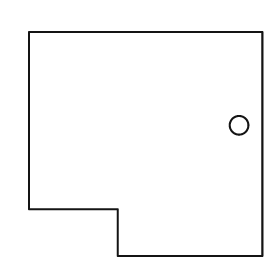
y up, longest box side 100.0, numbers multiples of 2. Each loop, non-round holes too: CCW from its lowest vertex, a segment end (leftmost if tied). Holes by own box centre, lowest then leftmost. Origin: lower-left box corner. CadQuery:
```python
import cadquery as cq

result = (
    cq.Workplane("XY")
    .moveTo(38.0, 0.0)
    .lineTo(100.0, 0.0)
    .lineTo(100.0, 96.0)
    .lineTo(0.0, 96.0)
    .lineTo(0.0, 20.0)
    .lineTo(38.0, 20.0)
    .close()
    .moveTo(90.0, 56.0)
    .circle(4.0)
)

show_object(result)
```